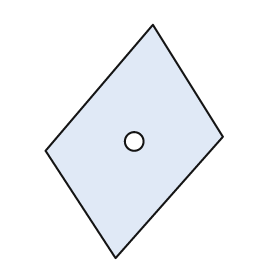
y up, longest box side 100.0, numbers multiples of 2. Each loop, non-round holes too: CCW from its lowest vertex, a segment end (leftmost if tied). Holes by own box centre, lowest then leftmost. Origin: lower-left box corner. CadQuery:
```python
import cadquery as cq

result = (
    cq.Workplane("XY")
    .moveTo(30.0, 0.0)
    .lineTo(76.0, 52.0)
    .lineTo(46.0, 100.0)
    .lineTo(0.0, 46.0)
    .close()
    .moveTo(38.0, 50.0)
    .circle(4.0)
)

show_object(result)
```